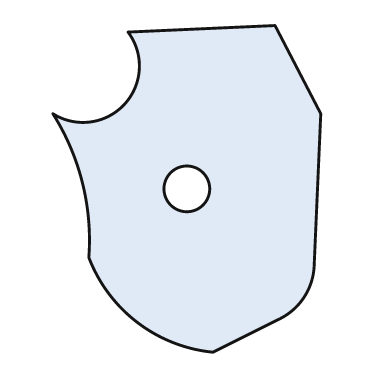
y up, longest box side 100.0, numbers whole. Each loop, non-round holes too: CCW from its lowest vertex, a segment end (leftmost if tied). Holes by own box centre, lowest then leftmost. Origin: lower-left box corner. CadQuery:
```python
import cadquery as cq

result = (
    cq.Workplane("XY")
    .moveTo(49.0, 0.0)
    .lineTo(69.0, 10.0)
    .threePointArc((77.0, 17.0), (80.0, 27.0))
    .lineTo(82.0, 73.0)
    .lineTo(68.0, 100.0)
    .lineTo(23.0, 98.0)
    .threePointArc((22.0, 76.0), (0.0, 73.0))
    .threePointArc((9.0, 52.0), (11.0, 29.0))
    .threePointArc((26.0, 9.0), (49.0, 0.0))
    .close()
    .moveTo(41.0, 50.0)
    .circle(7.0)
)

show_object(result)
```